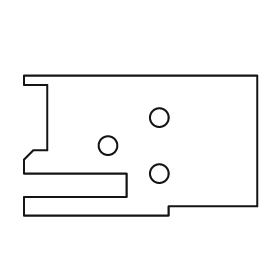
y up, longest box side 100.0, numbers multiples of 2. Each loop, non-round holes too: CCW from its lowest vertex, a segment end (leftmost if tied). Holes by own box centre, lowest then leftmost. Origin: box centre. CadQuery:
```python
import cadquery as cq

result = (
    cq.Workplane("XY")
    .moveTo(-50.0, -30.0)
    .lineTo(12.0, -30.0)
    .lineTo(12.0, -26.0)
    .lineTo(50.0, -26.0)
    .lineTo(50.0, 30.0)
    .lineTo(-50.0, 30.0)
    .lineTo(-50.0, 26.0)
    .lineTo(-40.0, 26.0)
    .lineTo(-40.0, -2.0)
    .lineTo(-46.0, -2.0)
    .lineTo(-50.0, -6.0)
    .lineTo(-50.0, -12.0)
    .lineTo(-6.0, -12.0)
    .lineTo(-6.0, -22.0)
    .lineTo(-50.0, -22.0)
    .close()
    .moveTo(8.0, -12.0)
    .circle(4.0)
    .moveTo(-14.0, 0.0)
    .circle(4.0)
    .moveTo(8.0, 12.0)
    .circle(4.0)
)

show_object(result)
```